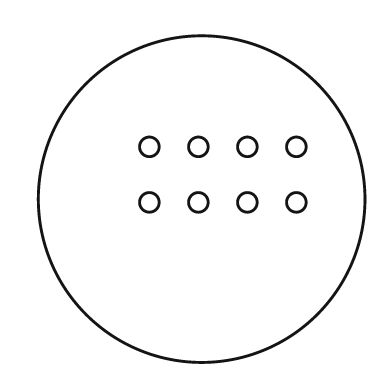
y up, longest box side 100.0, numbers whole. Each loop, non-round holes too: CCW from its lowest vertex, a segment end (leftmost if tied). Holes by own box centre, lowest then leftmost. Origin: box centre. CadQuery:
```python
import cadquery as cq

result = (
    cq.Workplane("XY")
    .moveTo(0.0, 0.0)
    .circle(50.0)
    .moveTo(-16.0, -1.0)
    .circle(3.0)
    .moveTo(-1.0, -1.0)
    .circle(3.0)
    .moveTo(14.0, -1.0)
    .circle(3.0)
    .moveTo(29.0, -1.0)
    .circle(3.0)
    .moveTo(-16.0, 16.0)
    .circle(3.0)
    .moveTo(-1.0, 16.0)
    .circle(3.0)
    .moveTo(14.0, 16.0)
    .circle(3.0)
    .moveTo(29.0, 16.0)
    .circle(3.0)
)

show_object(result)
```